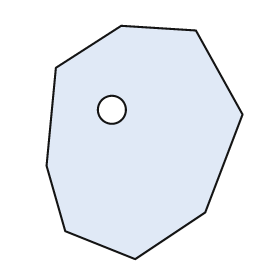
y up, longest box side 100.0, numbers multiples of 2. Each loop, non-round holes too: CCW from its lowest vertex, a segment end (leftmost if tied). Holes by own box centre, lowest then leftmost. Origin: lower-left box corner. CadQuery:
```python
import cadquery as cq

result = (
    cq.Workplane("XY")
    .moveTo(38.0, 0.0)
    .lineTo(68.0, 20.0)
    .lineTo(84.0, 62.0)
    .lineTo(64.0, 98.0)
    .lineTo(32.0, 100.0)
    .lineTo(4.0, 82.0)
    .lineTo(0.0, 40.0)
    .lineTo(8.0, 12.0)
    .close()
    .moveTo(28.0, 64.0)
    .circle(6.0)
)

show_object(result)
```